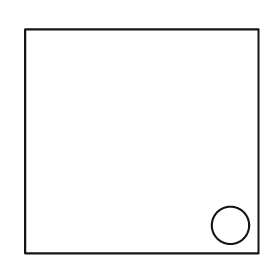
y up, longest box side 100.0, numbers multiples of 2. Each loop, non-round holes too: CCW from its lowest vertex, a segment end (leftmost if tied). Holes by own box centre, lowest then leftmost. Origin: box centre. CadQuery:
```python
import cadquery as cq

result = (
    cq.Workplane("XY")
    .moveTo(-50.0, -48.0)
    .lineTo(50.0, -48.0)
    .lineTo(50.0, 48.0)
    .lineTo(-50.0, 48.0)
    .close()
    .moveTo(38.0, -36.0)
    .circle(8.0)
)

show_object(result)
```